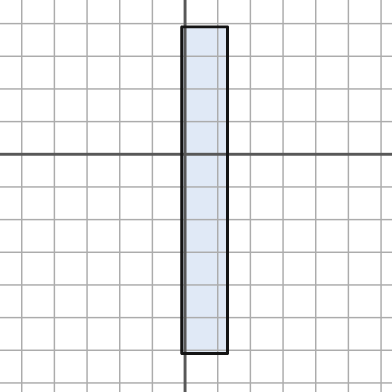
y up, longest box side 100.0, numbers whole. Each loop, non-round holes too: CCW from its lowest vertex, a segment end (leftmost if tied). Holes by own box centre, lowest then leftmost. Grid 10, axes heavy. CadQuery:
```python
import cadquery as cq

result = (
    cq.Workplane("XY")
    .moveTo(-1.0, -61.0)
    .lineTo(13.0, -61.0)
    .lineTo(13.0, 39.0)
    .lineTo(-1.0, 39.0)
    .close()
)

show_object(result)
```